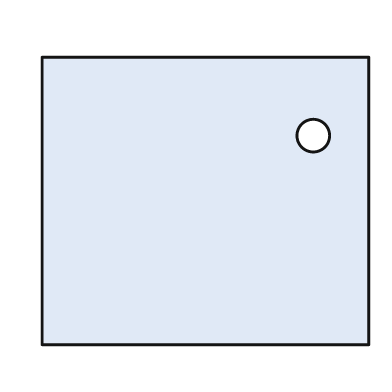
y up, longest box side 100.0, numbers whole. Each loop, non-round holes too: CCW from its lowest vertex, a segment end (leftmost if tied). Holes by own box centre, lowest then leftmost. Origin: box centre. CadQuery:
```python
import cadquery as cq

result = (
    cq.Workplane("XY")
    .moveTo(-50.0, -44.0)
    .lineTo(50.0, -44.0)
    .lineTo(50.0, 44.0)
    .lineTo(-50.0, 44.0)
    .close()
    .moveTo(33.0, 20.0)
    .circle(5.0)
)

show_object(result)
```